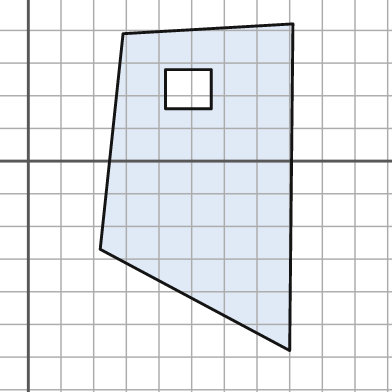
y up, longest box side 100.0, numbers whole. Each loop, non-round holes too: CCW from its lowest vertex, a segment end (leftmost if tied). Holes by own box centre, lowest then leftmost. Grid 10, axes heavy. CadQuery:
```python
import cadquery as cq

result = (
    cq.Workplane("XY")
    .moveTo(80.0, -58.0)
    .lineTo(81.0, 42.0)
    .lineTo(29.0, 39.0)
    .lineTo(22.0, -27.0)
    .close()
    .moveTo(42.0, 16.0)
    .lineTo(56.0, 16.0)
    .lineTo(56.0, 28.0)
    .lineTo(42.0, 28.0)
    .close()
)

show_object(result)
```